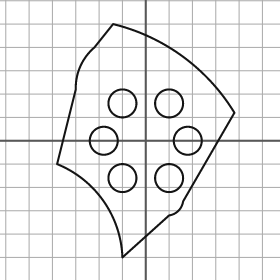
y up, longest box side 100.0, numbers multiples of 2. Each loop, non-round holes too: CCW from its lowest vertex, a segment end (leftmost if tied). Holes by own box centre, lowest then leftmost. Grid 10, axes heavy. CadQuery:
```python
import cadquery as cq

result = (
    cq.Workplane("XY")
    .moveTo(-10.0, -50.0)
    .lineTo(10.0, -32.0)
    .threePointArc((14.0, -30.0), (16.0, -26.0))
    .lineTo(38.0, 12.0)
    .threePointArc((16.0, 36.0), (-14.0, 50.0))
    .lineTo(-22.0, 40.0)
    .threePointArc((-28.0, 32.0), (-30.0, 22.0))
    .lineTo(-38.0, -10.0)
    .threePointArc((-18.0, -26.0), (-10.0, -50.0))
    .close()
    .moveTo(-10.0, -16.0)
    .circle(6.0)
    .moveTo(10.0, -16.0)
    .circle(6.0)
    .moveTo(-18.0, 0.0)
    .circle(6.0)
    .moveTo(18.0, 0.0)
    .circle(6.0)
    .moveTo(-10.0, 16.0)
    .circle(6.0)
    .moveTo(10.0, 16.0)
    .circle(6.0)
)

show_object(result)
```